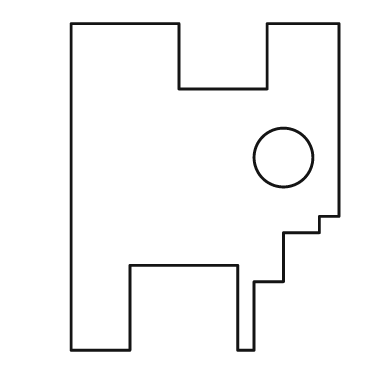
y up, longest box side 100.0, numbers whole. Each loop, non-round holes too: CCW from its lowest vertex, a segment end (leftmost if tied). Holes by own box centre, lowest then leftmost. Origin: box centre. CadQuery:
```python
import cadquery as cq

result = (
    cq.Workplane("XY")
    .moveTo(-41.0, -50.0)
    .lineTo(-23.0, -50.0)
    .lineTo(-23.0, -24.0)
    .lineTo(10.0, -24.0)
    .lineTo(10.0, -50.0)
    .lineTo(15.0, -50.0)
    .lineTo(15.0, -29.0)
    .lineTo(24.0, -29.0)
    .lineTo(24.0, -14.0)
    .lineTo(35.0, -14.0)
    .lineTo(35.0, -9.0)
    .lineTo(41.0, -9.0)
    .lineTo(41.0, 50.0)
    .lineTo(19.0, 50.0)
    .lineTo(19.0, 30.0)
    .lineTo(-8.0, 30.0)
    .lineTo(-8.0, 50.0)
    .lineTo(-41.0, 50.0)
    .close()
    .moveTo(24.0, 9.0)
    .circle(9.0)
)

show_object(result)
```